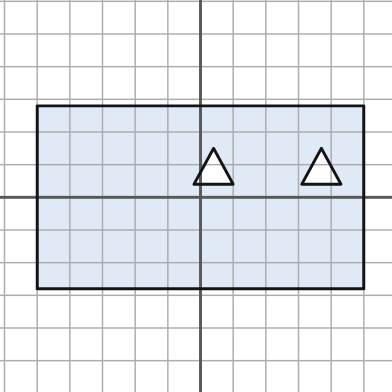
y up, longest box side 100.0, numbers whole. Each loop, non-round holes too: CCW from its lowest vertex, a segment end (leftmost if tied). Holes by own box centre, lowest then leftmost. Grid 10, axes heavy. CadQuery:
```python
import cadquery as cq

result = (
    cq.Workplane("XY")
    .moveTo(-50.0, -28.0)
    .lineTo(50.0, -28.0)
    .lineTo(50.0, 28.0)
    .lineTo(-50.0, 28.0)
    .close()
    .moveTo(-2.0, 4.0)
    .lineTo(10.0, 4.0)
    .lineTo(4.0, 15.0)
    .close()
    .moveTo(31.0, 4.0)
    .lineTo(43.0, 4.0)
    .lineTo(37.0, 15.0)
    .close()
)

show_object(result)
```